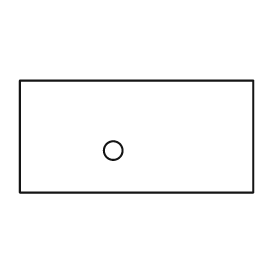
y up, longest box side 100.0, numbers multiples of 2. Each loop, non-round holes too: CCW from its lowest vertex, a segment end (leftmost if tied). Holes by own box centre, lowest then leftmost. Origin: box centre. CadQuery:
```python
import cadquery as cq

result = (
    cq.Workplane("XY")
    .moveTo(-50.0, -24.0)
    .lineTo(50.0, -24.0)
    .lineTo(50.0, 24.0)
    .lineTo(-50.0, 24.0)
    .close()
    .moveTo(-10.0, -6.0)
    .circle(4.0)
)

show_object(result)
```